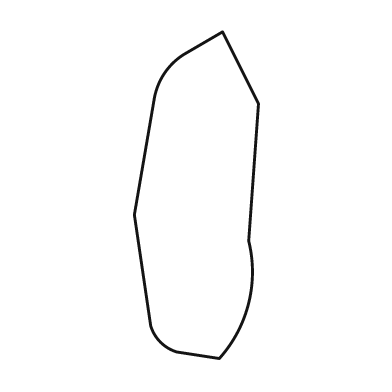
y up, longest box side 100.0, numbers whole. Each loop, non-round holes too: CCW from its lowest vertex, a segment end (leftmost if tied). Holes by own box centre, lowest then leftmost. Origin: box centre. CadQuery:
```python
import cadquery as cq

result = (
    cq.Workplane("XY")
    .moveTo(7.0, -50.0)
    .threePointArc((16.0, -33.0), (16.0, -14.0))
    .lineTo(19.0, 28.0)
    .lineTo(8.0, 50.0)
    .lineTo(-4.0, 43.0)
    .threePointArc((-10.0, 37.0), (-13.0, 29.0))
    .lineTo(-19.0, -6.0)
    .lineTo(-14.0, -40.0)
    .threePointArc((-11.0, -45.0), (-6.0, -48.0))
    .close()
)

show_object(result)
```